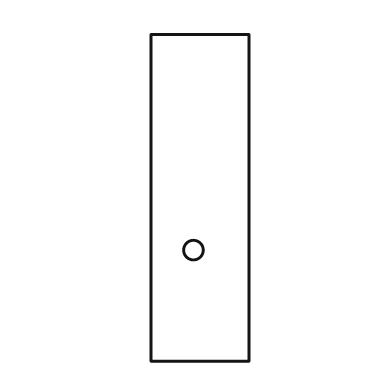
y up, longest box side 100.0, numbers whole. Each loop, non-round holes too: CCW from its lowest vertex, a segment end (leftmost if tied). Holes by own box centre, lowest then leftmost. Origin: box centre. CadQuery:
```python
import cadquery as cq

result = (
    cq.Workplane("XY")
    .moveTo(-15.0, -50.0)
    .lineTo(15.0, -50.0)
    .lineTo(15.0, 50.0)
    .lineTo(-15.0, 50.0)
    .close()
    .moveTo(-2.0, -16.0)
    .circle(3.0)
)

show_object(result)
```